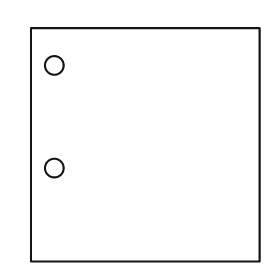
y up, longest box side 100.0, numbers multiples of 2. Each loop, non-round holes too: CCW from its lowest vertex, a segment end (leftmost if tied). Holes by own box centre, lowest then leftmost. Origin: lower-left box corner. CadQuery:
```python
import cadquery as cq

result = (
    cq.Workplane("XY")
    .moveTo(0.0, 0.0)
    .lineTo(98.0, 0.0)
    .lineTo(98.0, 100.0)
    .lineTo(0.0, 100.0)
    .close()
    .moveTo(10.0, 40.0)
    .circle(4.0)
    .moveTo(10.0, 84.0)
    .circle(4.0)
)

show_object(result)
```